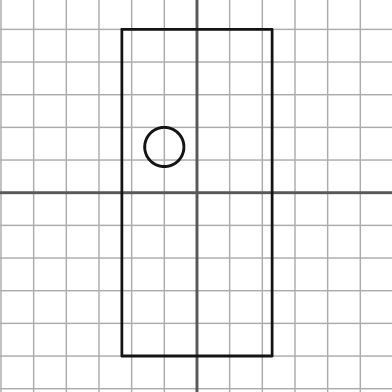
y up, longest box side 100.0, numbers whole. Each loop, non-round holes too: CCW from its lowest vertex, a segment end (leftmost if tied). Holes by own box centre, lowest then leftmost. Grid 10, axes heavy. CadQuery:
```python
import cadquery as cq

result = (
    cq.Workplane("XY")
    .moveTo(-23.0, -50.0)
    .lineTo(23.0, -50.0)
    .lineTo(23.0, 50.0)
    .lineTo(-23.0, 50.0)
    .close()
    .moveTo(-10.0, 14.0)
    .circle(6.0)
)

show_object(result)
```